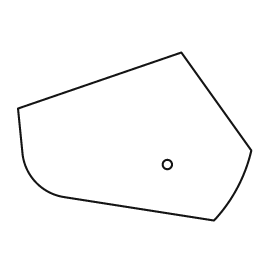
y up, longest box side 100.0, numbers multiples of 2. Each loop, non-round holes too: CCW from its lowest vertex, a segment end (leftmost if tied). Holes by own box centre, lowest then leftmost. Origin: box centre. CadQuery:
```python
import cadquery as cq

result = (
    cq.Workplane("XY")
    .moveTo(34.0, -36.0)
    .threePointArc((44.0, -22.0), (50.0, -6.0))
    .lineTo(20.0, 36.0)
    .lineTo(-50.0, 12.0)
    .lineTo(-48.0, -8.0)
    .threePointArc((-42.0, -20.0), (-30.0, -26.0))
    .close()
    .moveTo(14.0, -12.0)
    .circle(2.0)
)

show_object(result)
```